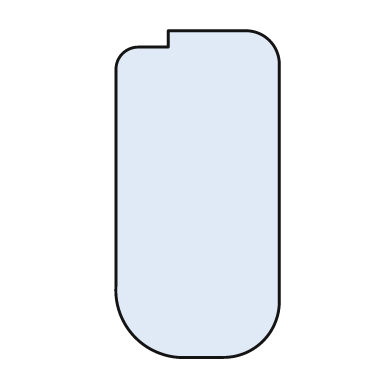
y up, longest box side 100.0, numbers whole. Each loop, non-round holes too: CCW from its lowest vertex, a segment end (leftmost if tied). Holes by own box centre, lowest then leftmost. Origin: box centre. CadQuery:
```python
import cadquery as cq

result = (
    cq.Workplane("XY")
    .moveTo(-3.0, -50.0)
    .lineTo(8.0, -50.0)
    .threePointArc((20.0, -45.0), (25.0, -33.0))
    .lineTo(25.0, 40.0)
    .threePointArc((22.0, 47.0), (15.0, 50.0))
    .lineTo(-9.0, 50.0)
    .lineTo(-9.0, 45.0)
    .lineTo(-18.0, 45.0)
    .threePointArc((-23.0, 43.0), (-25.0, 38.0))
    .lineTo(-25.0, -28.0)
    .threePointArc((-19.0, -44.0), (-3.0, -50.0))
    .close()
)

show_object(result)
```